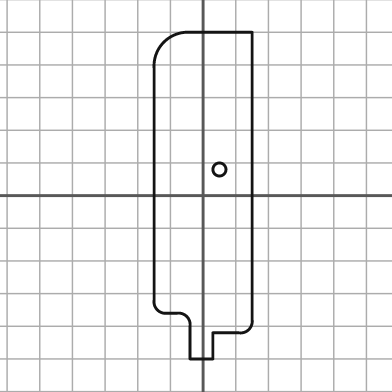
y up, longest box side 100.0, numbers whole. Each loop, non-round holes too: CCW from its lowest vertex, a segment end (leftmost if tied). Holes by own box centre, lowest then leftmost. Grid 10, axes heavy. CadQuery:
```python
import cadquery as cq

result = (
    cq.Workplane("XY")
    .moveTo(-4.0, -50.0)
    .lineTo(3.0, -50.0)
    .lineTo(3.0, -42.0)
    .lineTo(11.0, -42.0)
    .threePointArc((14.0, -41.0), (15.0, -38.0))
    .lineTo(15.0, 50.0)
    .lineTo(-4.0, 50.0)
    .threePointArc((-12.0, 47.0), (-15.0, 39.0))
    .lineTo(-15.0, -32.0)
    .threePointArc((-14.0, -35.0), (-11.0, -36.0))
    .lineTo(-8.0, -36.0)
    .threePointArc((-5.0, -37.0), (-4.0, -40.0))
    .close()
    .moveTo(5.0, 8.0)
    .circle(2.0)
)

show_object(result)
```